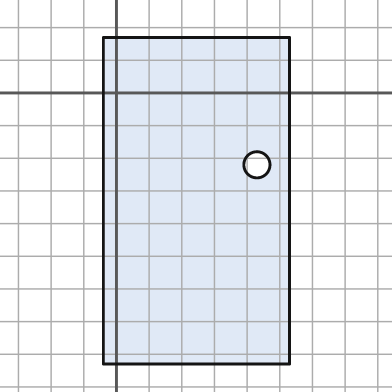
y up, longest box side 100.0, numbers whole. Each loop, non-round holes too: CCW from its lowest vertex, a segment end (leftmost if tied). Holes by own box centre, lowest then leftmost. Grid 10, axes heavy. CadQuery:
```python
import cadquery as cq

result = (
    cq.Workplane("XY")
    .moveTo(-4.0, -83.0)
    .lineTo(53.0, -83.0)
    .lineTo(53.0, 17.0)
    .lineTo(-4.0, 17.0)
    .close()
    .moveTo(43.0, -22.0)
    .circle(4.0)
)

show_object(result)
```